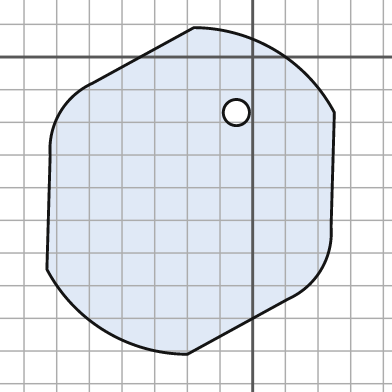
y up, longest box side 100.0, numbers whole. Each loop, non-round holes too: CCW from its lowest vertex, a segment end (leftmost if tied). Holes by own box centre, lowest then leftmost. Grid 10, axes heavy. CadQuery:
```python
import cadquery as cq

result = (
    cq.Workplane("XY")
    .moveTo(-20.0, -91.0)
    .lineTo(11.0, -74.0)
    .threePointArc((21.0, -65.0), (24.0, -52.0))
    .lineTo(25.0, -17.0)
    .threePointArc((7.0, 2.0), (-18.0, 9.0))
    .lineTo(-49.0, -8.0)
    .threePointArc((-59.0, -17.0), (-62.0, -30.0))
    .lineTo(-63.0, -65.0)
    .threePointArc((-45.0, -84.0), (-20.0, -91.0))
    .close()
    .moveTo(-5.0, -17.0)
    .circle(4.0)
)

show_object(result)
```